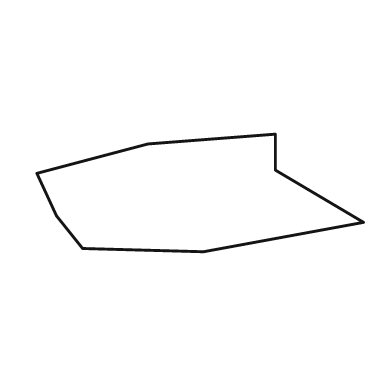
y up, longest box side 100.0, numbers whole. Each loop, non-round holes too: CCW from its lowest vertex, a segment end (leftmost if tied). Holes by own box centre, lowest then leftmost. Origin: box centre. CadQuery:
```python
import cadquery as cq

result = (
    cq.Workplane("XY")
    .moveTo(1.0, -18.0)
    .lineTo(50.0, -9.0)
    .lineTo(23.0, 7.0)
    .lineTo(23.0, 18.0)
    .lineTo(-16.0, 15.0)
    .lineTo(-50.0, 6.0)
    .lineTo(-44.0, -7.0)
    .lineTo(-36.0, -17.0)
    .close()
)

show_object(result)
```